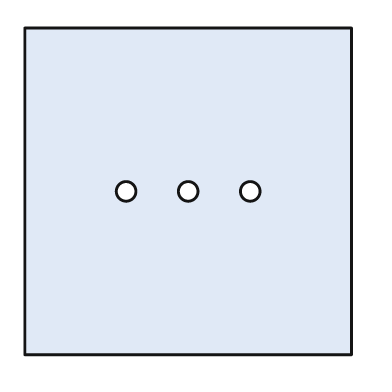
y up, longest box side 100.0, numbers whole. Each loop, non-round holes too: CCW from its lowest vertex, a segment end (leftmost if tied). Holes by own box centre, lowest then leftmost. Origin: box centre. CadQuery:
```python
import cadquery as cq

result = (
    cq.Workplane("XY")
    .moveTo(-50.0, -50.0)
    .lineTo(50.0, -50.0)
    .lineTo(50.0, 50.0)
    .lineTo(-50.0, 50.0)
    .close()
    .moveTo(-19.0, 0.0)
    .circle(3.0)
    .moveTo(0.0, 0.0)
    .circle(3.0)
    .moveTo(19.0, 0.0)
    .circle(3.0)
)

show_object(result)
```